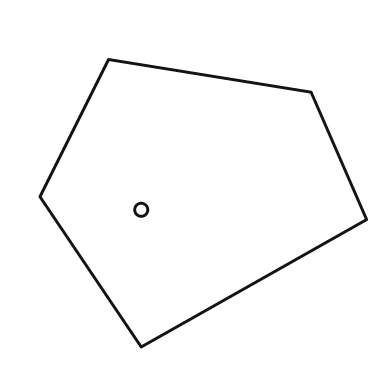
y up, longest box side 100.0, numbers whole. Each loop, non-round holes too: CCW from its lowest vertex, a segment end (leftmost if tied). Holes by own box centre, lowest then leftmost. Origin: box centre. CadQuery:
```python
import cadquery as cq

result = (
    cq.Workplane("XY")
    .moveTo(-19.0, -44.0)
    .lineTo(50.0, -5.0)
    .lineTo(33.0, 34.0)
    .lineTo(-29.0, 44.0)
    .lineTo(-50.0, 2.0)
    .close()
    .moveTo(-19.0, -2.0)
    .circle(2.0)
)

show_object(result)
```